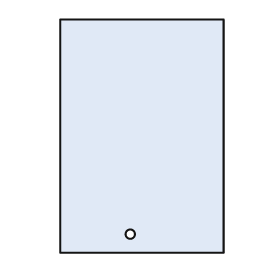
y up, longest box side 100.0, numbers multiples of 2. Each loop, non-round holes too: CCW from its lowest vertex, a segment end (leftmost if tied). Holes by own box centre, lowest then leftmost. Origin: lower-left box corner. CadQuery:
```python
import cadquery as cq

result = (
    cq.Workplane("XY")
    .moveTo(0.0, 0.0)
    .lineTo(70.0, 0.0)
    .lineTo(70.0, 100.0)
    .lineTo(0.0, 100.0)
    .close()
    .moveTo(30.0, 8.0)
    .circle(2.0)
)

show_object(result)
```